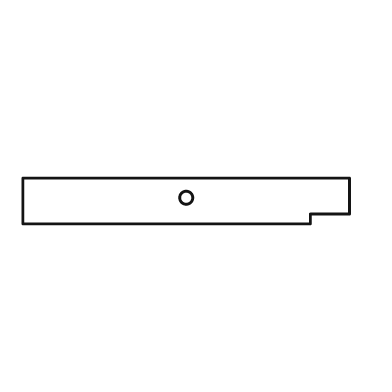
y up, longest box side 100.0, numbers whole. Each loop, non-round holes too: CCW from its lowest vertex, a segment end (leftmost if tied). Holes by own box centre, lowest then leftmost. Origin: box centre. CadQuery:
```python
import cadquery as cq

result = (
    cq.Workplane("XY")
    .moveTo(-50.0, -7.0)
    .lineTo(38.0, -7.0)
    .lineTo(38.0, -4.0)
    .lineTo(50.0, -4.0)
    .lineTo(50.0, 7.0)
    .lineTo(-50.0, 7.0)
    .close()
    .moveTo(0.0, 1.0)
    .circle(2.0)
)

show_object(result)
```